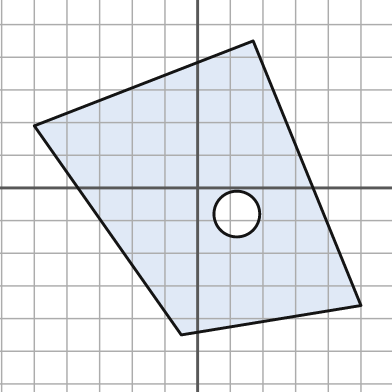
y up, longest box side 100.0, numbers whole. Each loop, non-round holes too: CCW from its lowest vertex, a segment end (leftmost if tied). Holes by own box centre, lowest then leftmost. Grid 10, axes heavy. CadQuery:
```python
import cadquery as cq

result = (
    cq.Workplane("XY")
    .moveTo(-5.0, -45.0)
    .lineTo(50.0, -36.0)
    .lineTo(17.0, 45.0)
    .lineTo(-50.0, 19.0)
    .close()
    .moveTo(12.0, -8.0)
    .circle(7.0)
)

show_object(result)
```